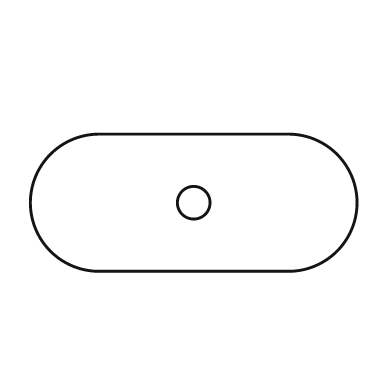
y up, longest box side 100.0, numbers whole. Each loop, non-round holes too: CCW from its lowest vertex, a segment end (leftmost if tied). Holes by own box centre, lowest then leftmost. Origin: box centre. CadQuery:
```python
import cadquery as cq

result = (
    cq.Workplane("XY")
    .moveTo(-29.0, -21.0)
    .lineTo(29.0, -21.0)
    .threePointArc((50.0, 0.0), (29.0, 21.0))
    .lineTo(-29.0, 21.0)
    .threePointArc((-50.0, 0.0), (-29.0, -21.0))
    .close()
    .moveTo(0.0, 0.0)
    .circle(5.0)
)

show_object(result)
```